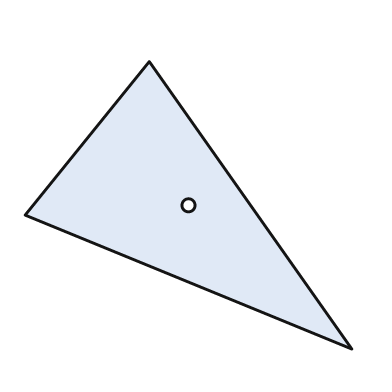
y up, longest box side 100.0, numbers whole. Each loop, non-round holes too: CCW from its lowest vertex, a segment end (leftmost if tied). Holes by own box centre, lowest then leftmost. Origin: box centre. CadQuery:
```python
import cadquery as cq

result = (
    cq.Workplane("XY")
    .moveTo(50.0, -44.0)
    .lineTo(-12.0, 44.0)
    .lineTo(-50.0, -3.0)
    .close()
    .moveTo(0.0, 0.0)
    .circle(2.0)
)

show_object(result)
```